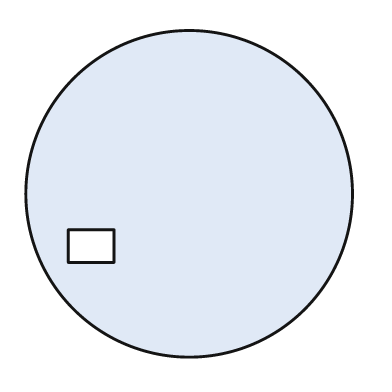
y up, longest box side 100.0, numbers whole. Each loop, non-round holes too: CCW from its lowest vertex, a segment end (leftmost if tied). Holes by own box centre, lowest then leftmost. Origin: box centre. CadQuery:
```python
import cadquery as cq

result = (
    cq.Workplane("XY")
    .moveTo(0.0, 0.0)
    .circle(50.0)
    .moveTo(-37.0, -21.0)
    .lineTo(-23.0, -21.0)
    .lineTo(-23.0, -11.0)
    .lineTo(-37.0, -11.0)
    .close()
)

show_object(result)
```